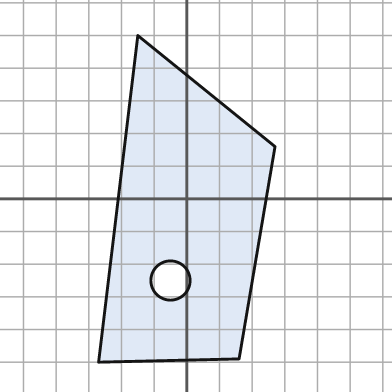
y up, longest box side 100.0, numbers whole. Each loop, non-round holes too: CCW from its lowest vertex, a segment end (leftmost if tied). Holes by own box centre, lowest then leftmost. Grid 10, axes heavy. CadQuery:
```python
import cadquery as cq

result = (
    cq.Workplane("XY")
    .moveTo(-27.0, -50.0)
    .lineTo(16.0, -49.0)
    .lineTo(27.0, 16.0)
    .lineTo(-15.0, 50.0)
    .close()
    .moveTo(-5.0, -25.0)
    .circle(6.0)
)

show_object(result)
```